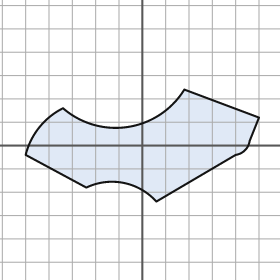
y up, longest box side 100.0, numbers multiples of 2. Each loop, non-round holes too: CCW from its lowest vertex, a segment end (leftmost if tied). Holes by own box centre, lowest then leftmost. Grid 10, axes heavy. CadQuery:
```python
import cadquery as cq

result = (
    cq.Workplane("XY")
    .moveTo(6.0, -24.0)
    .lineTo(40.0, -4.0)
    .threePointArc((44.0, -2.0), (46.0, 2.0))
    .lineTo(50.0, 12.0)
    .lineTo(18.0, 24.0)
    .threePointArc((-6.0, 8.0), (-34.0, 16.0))
    .threePointArc((-44.0, 8.0), (-50.0, -4.0))
    .lineTo(-24.0, -18.0)
    .threePointArc((-8.0, -16.0), (6.0, -24.0))
    .close()
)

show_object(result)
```